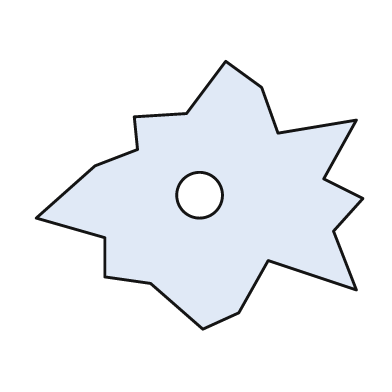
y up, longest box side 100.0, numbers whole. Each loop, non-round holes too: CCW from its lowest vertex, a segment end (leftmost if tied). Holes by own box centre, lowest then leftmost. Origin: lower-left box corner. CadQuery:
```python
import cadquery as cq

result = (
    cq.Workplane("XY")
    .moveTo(51.0, 0.0)
    .lineTo(62.0, 5.0)
    .lineTo(71.0, 21.0)
    .lineTo(98.0, 12.0)
    .lineTo(91.0, 30.0)
    .lineTo(100.0, 40.0)
    .lineTo(88.0, 46.0)
    .lineTo(98.0, 64.0)
    .lineTo(74.0, 60.0)
    .lineTo(69.0, 74.0)
    .lineTo(58.0, 82.0)
    .lineTo(46.0, 66.0)
    .lineTo(30.0, 65.0)
    .lineTo(31.0, 55.0)
    .lineTo(18.0, 50.0)
    .lineTo(0.0, 34.0)
    .lineTo(21.0, 28.0)
    .lineTo(21.0, 16.0)
    .lineTo(35.0, 14.0)
    .close()
    .moveTo(50.0, 41.0)
    .circle(7.0)
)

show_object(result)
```